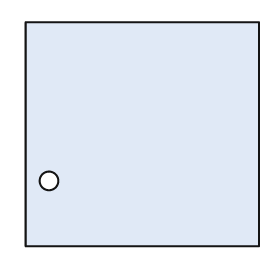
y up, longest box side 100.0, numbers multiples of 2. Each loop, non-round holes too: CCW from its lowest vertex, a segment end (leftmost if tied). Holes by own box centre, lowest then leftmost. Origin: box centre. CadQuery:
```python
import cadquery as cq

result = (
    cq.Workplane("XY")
    .moveTo(-50.0, -48.0)
    .lineTo(50.0, -48.0)
    .lineTo(50.0, 48.0)
    .lineTo(-50.0, 48.0)
    .close()
    .moveTo(-40.0, -20.0)
    .circle(4.0)
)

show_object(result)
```